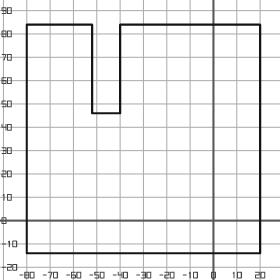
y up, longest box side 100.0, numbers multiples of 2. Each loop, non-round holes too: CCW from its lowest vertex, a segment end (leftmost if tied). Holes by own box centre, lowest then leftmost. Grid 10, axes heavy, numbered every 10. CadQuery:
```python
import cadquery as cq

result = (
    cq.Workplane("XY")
    .moveTo(-80.0, -14.0)
    .lineTo(20.0, -14.0)
    .lineTo(20.0, 84.0)
    .lineTo(-40.0, 84.0)
    .lineTo(-40.0, 46.0)
    .lineTo(-52.0, 46.0)
    .lineTo(-52.0, 84.0)
    .lineTo(-80.0, 84.0)
    .close()
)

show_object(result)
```